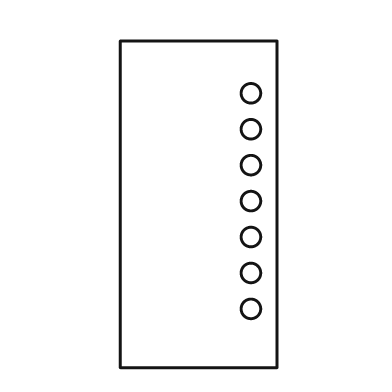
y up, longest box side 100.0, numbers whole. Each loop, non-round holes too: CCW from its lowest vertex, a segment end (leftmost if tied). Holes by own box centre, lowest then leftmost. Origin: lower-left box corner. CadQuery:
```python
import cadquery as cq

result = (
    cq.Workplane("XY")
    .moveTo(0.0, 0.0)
    .lineTo(48.0, 0.0)
    .lineTo(48.0, 100.0)
    .lineTo(0.0, 100.0)
    .close()
    .moveTo(40.0, 18.0)
    .circle(3.0)
    .moveTo(40.0, 29.0)
    .circle(3.0)
    .moveTo(40.0, 40.0)
    .circle(3.0)
    .moveTo(40.0, 51.0)
    .circle(3.0)
    .moveTo(40.0, 62.0)
    .circle(3.0)
    .moveTo(40.0, 73.0)
    .circle(3.0)
    .moveTo(40.0, 84.0)
    .circle(3.0)
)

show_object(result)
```